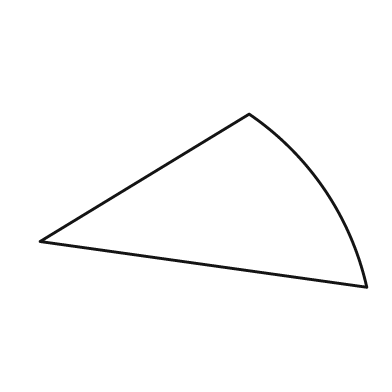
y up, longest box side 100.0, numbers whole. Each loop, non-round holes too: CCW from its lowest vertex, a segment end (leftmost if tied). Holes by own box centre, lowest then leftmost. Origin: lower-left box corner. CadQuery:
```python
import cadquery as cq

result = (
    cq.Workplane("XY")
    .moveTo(100.0, 0.0)
    .threePointArc((87.0, 30.0), (64.0, 53.0))
    .lineTo(0.0, 14.0)
    .close()
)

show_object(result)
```